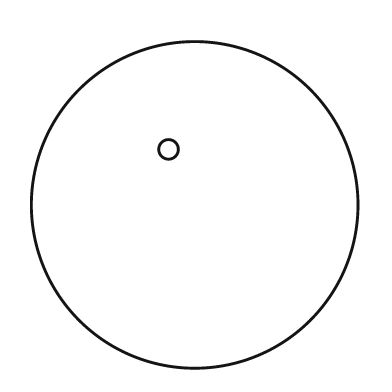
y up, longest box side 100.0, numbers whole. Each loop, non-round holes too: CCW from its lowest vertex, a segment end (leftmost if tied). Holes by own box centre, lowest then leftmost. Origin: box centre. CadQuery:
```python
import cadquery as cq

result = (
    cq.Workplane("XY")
    .moveTo(0.0, 0.0)
    .circle(50.0)
    .moveTo(-8.0, 17.0)
    .circle(3.0)
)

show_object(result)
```